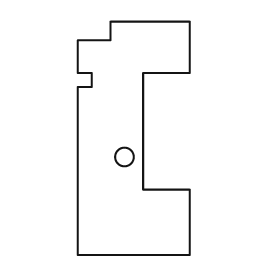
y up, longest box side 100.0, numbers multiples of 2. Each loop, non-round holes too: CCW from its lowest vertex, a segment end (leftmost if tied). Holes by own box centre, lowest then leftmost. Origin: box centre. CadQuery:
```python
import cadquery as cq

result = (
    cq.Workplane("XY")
    .moveTo(-24.0, -50.0)
    .lineTo(24.0, -50.0)
    .lineTo(24.0, -22.0)
    .lineTo(4.0, -22.0)
    .lineTo(4.0, 28.0)
    .lineTo(24.0, 28.0)
    .lineTo(24.0, 50.0)
    .lineTo(-10.0, 50.0)
    .lineTo(-10.0, 42.0)
    .lineTo(-24.0, 42.0)
    .lineTo(-24.0, 28.0)
    .lineTo(-18.0, 28.0)
    .lineTo(-18.0, 22.0)
    .lineTo(-24.0, 22.0)
    .close()
    .moveTo(-4.0, -8.0)
    .circle(4.0)
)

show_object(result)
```